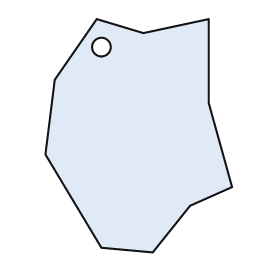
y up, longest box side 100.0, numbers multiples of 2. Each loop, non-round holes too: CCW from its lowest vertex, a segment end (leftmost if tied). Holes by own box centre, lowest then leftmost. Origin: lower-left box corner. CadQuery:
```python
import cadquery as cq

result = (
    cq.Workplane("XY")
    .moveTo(46.0, 0.0)
    .lineTo(62.0, 20.0)
    .lineTo(80.0, 28.0)
    .lineTo(70.0, 64.0)
    .lineTo(70.0, 100.0)
    .lineTo(42.0, 94.0)
    .lineTo(22.0, 100.0)
    .lineTo(4.0, 74.0)
    .lineTo(0.0, 42.0)
    .lineTo(24.0, 2.0)
    .close()
    .moveTo(24.0, 88.0)
    .circle(4.0)
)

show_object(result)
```